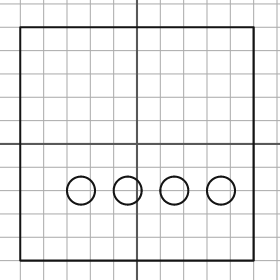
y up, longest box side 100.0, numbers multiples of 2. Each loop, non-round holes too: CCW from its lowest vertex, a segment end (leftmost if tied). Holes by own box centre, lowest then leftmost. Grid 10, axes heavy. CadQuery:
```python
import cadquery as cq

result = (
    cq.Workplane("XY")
    .moveTo(-50.0, -50.0)
    .lineTo(50.0, -50.0)
    .lineTo(50.0, 50.0)
    .lineTo(-50.0, 50.0)
    .close()
    .moveTo(-24.0, -20.0)
    .circle(6.0)
    .moveTo(-4.0, -20.0)
    .circle(6.0)
    .moveTo(16.0, -20.0)
    .circle(6.0)
    .moveTo(36.0, -20.0)
    .circle(6.0)
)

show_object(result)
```